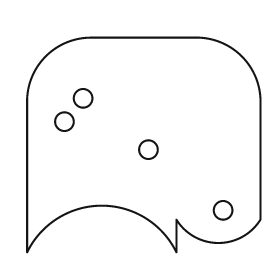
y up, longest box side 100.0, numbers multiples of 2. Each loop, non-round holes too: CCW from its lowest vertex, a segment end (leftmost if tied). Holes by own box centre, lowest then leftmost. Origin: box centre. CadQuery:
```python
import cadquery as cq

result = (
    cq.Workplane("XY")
    .moveTo(-50.0, -46.0)
    .threePointArc((-18.0, -26.0), (14.0, -46.0))
    .lineTo(14.0, -32.0)
    .threePointArc((32.0, -42.0), (50.0, -32.0))
    .lineTo(50.0, 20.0)
    .threePointArc((42.0, 38.0), (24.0, 46.0))
    .lineTo(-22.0, 46.0)
    .threePointArc((-42.0, 38.0), (-50.0, 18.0))
    .close()
    .moveTo(34.0, -28.0)
    .circle(4.0)
    .moveTo(2.0, -2.0)
    .circle(4.0)
    .moveTo(-34.0, 10.0)
    .circle(4.0)
    .moveTo(-26.0, 20.0)
    .circle(4.0)
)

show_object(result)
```